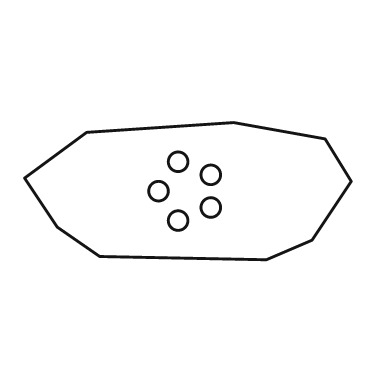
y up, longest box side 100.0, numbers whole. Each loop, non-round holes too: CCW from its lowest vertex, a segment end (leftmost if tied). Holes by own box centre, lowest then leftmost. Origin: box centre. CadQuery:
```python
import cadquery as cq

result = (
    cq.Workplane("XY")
    .moveTo(24.0, -21.0)
    .lineTo(38.0, -15.0)
    .lineTo(50.0, 3.0)
    .lineTo(42.0, 16.0)
    .lineTo(14.0, 21.0)
    .lineTo(-31.0, 18.0)
    .lineTo(-50.0, 4.0)
    .lineTo(-40.0, -11.0)
    .lineTo(-27.0, -20.0)
    .close()
    .moveTo(-3.0, -9.0)
    .circle(3.0)
    .moveTo(7.0, -5.0)
    .circle(3.0)
    .moveTo(-9.0, 0.0)
    .circle(3.0)
    .moveTo(7.0, 5.0)
    .circle(3.0)
    .moveTo(-3.0, 9.0)
    .circle(3.0)
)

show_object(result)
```